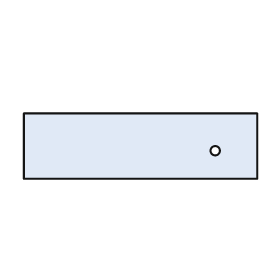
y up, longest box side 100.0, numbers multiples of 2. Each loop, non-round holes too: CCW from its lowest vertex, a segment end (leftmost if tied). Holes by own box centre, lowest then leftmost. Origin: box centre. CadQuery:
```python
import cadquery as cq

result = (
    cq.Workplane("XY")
    .moveTo(-50.0, -14.0)
    .lineTo(50.0, -14.0)
    .lineTo(50.0, 14.0)
    .lineTo(-50.0, 14.0)
    .close()
    .moveTo(32.0, -2.0)
    .circle(2.0)
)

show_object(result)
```